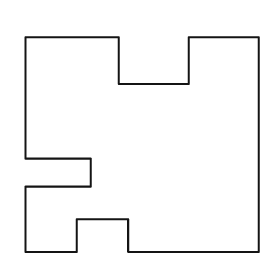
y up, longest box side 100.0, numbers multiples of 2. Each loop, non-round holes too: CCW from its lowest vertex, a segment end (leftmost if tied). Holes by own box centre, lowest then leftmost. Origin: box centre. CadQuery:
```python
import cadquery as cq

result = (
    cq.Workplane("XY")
    .moveTo(-50.0, -46.0)
    .lineTo(-28.0, -46.0)
    .lineTo(-28.0, -32.0)
    .lineTo(-6.0, -32.0)
    .lineTo(-6.0, -46.0)
    .lineTo(50.0, -46.0)
    .lineTo(50.0, 46.0)
    .lineTo(20.0, 46.0)
    .lineTo(20.0, 26.0)
    .lineTo(-10.0, 26.0)
    .lineTo(-10.0, 46.0)
    .lineTo(-50.0, 46.0)
    .lineTo(-50.0, -6.0)
    .lineTo(-22.0, -6.0)
    .lineTo(-22.0, -18.0)
    .lineTo(-50.0, -18.0)
    .close()
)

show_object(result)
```